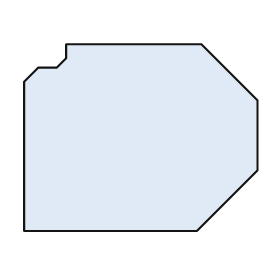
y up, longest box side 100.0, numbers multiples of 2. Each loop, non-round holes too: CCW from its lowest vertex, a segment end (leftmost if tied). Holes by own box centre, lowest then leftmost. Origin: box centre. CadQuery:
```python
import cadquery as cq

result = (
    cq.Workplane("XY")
    .moveTo(-50.0, -40.0)
    .lineTo(24.0, -40.0)
    .lineTo(50.0, -14.0)
    .lineTo(50.0, 16.0)
    .lineTo(26.0, 40.0)
    .lineTo(-32.0, 40.0)
    .lineTo(-32.0, 34.0)
    .lineTo(-36.0, 30.0)
    .lineTo(-44.0, 30.0)
    .lineTo(-50.0, 24.0)
    .close()
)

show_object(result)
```